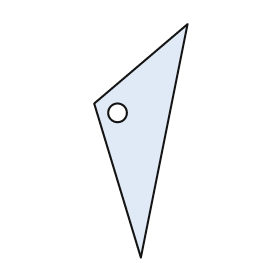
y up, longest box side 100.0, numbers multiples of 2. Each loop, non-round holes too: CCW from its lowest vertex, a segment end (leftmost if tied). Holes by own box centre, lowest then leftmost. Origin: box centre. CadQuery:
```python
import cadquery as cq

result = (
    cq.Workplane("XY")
    .moveTo(0.0, -50.0)
    .lineTo(20.0, 50.0)
    .lineTo(-20.0, 16.0)
    .close()
    .moveTo(-10.0, 12.0)
    .circle(4.0)
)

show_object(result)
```